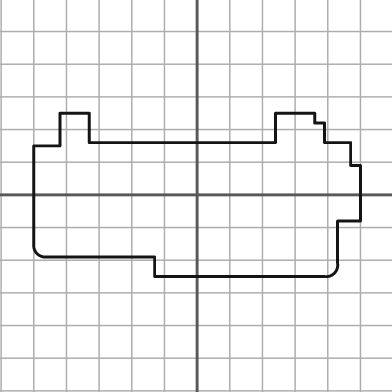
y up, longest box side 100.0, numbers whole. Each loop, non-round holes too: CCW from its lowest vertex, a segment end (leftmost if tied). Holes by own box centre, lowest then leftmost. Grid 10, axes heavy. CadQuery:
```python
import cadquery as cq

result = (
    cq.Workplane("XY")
    .moveTo(-13.0, -25.0)
    .lineTo(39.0, -25.0)
    .threePointArc((42.0, -24.0), (43.0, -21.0))
    .lineTo(43.0, -8.0)
    .lineTo(50.0, -8.0)
    .lineTo(50.0, 9.0)
    .lineTo(47.0, 9.0)
    .lineTo(47.0, 16.0)
    .lineTo(39.0, 16.0)
    .lineTo(39.0, 22.0)
    .lineTo(36.0, 22.0)
    .lineTo(36.0, 25.0)
    .lineTo(24.0, 25.0)
    .lineTo(24.0, 16.0)
    .lineTo(-33.0, 16.0)
    .lineTo(-33.0, 25.0)
    .lineTo(-42.0, 25.0)
    .lineTo(-42.0, 15.0)
    .lineTo(-50.0, 15.0)
    .lineTo(-50.0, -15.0)
    .threePointArc((-49.0, -18.0), (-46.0, -19.0))
    .lineTo(-13.0, -19.0)
    .close()
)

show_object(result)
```